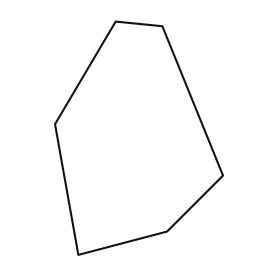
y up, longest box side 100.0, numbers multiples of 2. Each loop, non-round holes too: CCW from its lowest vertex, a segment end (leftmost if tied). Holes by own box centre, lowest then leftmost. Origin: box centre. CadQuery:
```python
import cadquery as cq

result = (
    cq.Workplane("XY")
    .moveTo(-26.0, -50.0)
    .lineTo(12.0, -40.0)
    .lineTo(36.0, -16.0)
    .lineTo(10.0, 48.0)
    .lineTo(-10.0, 50.0)
    .lineTo(-36.0, 6.0)
    .close()
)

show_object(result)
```